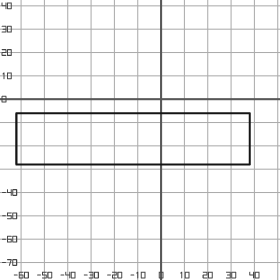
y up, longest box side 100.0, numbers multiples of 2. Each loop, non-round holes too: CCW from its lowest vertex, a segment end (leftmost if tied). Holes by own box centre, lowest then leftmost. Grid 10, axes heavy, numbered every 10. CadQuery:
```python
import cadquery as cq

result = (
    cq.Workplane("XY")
    .moveTo(-62.0, -28.0)
    .lineTo(38.0, -28.0)
    .lineTo(38.0, -6.0)
    .lineTo(-62.0, -6.0)
    .close()
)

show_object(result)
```